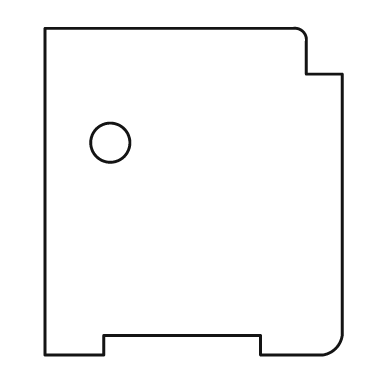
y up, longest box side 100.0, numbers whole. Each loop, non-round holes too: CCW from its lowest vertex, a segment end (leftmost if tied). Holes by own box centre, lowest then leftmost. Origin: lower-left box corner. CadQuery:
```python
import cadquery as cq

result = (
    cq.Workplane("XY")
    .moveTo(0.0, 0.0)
    .lineTo(18.0, 0.0)
    .lineTo(18.0, 6.0)
    .lineTo(66.0, 6.0)
    .lineTo(66.0, 0.0)
    .lineTo(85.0, 0.0)
    .threePointArc((89.0, 2.0), (91.0, 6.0))
    .lineTo(91.0, 86.0)
    .lineTo(80.0, 86.0)
    .lineTo(80.0, 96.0)
    .threePointArc((79.0, 99.0), (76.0, 100.0))
    .lineTo(0.0, 100.0)
    .close()
    .moveTo(20.0, 65.0)
    .circle(6.0)
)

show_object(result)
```